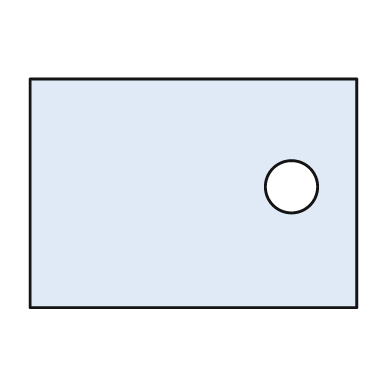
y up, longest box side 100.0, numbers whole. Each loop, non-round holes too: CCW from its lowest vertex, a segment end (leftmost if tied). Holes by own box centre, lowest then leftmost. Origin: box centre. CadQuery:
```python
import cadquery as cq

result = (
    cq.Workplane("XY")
    .moveTo(-50.0, -35.0)
    .lineTo(50.0, -35.0)
    .lineTo(50.0, 35.0)
    .lineTo(-50.0, 35.0)
    .close()
    .moveTo(30.0, 2.0)
    .circle(8.0)
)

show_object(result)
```